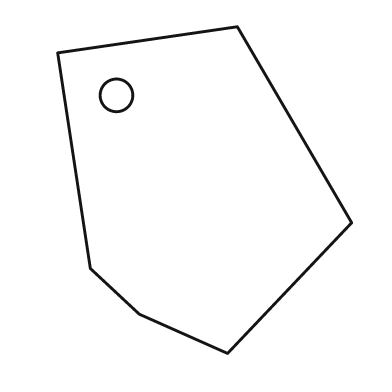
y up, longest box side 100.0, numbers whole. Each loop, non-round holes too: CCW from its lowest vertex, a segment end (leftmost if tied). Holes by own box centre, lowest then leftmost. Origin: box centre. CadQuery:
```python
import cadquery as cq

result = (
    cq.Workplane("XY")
    .moveTo(7.0, -50.0)
    .lineTo(45.0, -10.0)
    .lineTo(10.0, 50.0)
    .lineTo(-45.0, 42.0)
    .lineTo(-35.0, -24.0)
    .lineTo(-20.0, -38.0)
    .close()
    .moveTo(-27.0, 29.0)
    .circle(5.0)
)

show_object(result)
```